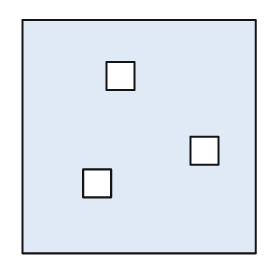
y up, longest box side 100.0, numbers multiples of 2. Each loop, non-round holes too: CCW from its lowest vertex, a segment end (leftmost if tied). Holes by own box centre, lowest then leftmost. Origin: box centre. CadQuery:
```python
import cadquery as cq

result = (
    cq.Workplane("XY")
    .moveTo(-50.0, -50.0)
    .lineTo(50.0, -50.0)
    .lineTo(50.0, 50.0)
    .lineTo(-50.0, 50.0)
    .close()
    .moveTo(-24.0, -26.0)
    .lineTo(-12.0, -26.0)
    .lineTo(-12.0, -14.0)
    .lineTo(-24.0, -14.0)
    .close()
    .moveTo(22.0, -12.0)
    .lineTo(34.0, -12.0)
    .lineTo(34.0, 0.0)
    .lineTo(22.0, 0.0)
    .close()
    .moveTo(-14.0, 20.0)
    .lineTo(-2.0, 20.0)
    .lineTo(-2.0, 32.0)
    .lineTo(-14.0, 32.0)
    .close()
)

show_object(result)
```